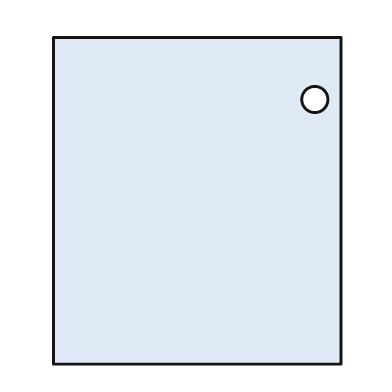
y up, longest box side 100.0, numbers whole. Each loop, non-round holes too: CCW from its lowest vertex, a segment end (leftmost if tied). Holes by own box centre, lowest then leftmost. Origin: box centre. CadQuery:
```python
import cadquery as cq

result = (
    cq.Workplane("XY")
    .moveTo(-44.0, -50.0)
    .lineTo(44.0, -50.0)
    .lineTo(44.0, 50.0)
    .lineTo(-44.0, 50.0)
    .close()
    .moveTo(36.0, 31.0)
    .circle(4.0)
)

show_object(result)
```